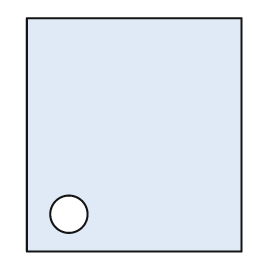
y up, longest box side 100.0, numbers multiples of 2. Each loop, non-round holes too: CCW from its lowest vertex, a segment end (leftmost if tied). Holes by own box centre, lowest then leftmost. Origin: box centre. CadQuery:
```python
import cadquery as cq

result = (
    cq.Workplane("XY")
    .moveTo(-46.0, -50.0)
    .lineTo(46.0, -50.0)
    .lineTo(46.0, 50.0)
    .lineTo(-46.0, 50.0)
    .close()
    .moveTo(-28.0, -34.0)
    .circle(8.0)
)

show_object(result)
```